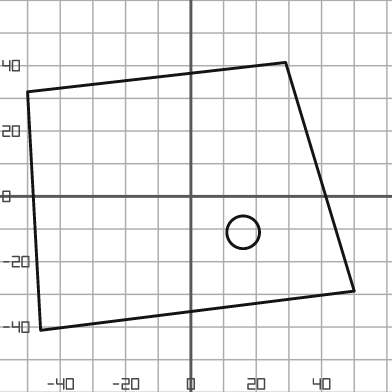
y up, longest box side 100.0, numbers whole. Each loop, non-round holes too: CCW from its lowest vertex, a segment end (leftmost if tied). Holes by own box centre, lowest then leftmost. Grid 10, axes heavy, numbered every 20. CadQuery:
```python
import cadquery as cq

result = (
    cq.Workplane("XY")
    .moveTo(-46.0, -41.0)
    .lineTo(50.0, -29.0)
    .lineTo(29.0, 41.0)
    .lineTo(-50.0, 32.0)
    .close()
    .moveTo(16.0, -11.0)
    .circle(5.0)
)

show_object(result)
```